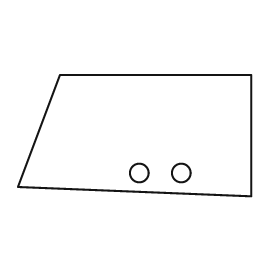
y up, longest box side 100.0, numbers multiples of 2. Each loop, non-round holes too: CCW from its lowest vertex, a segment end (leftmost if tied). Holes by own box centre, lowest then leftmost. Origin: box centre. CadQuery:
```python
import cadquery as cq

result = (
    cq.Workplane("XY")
    .moveTo(50.0, -26.0)
    .lineTo(50.0, 26.0)
    .lineTo(-32.0, 26.0)
    .lineTo(-50.0, -22.0)
    .close()
    .moveTo(2.0, -16.0)
    .circle(4.0)
    .moveTo(20.0, -16.0)
    .circle(4.0)
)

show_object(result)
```